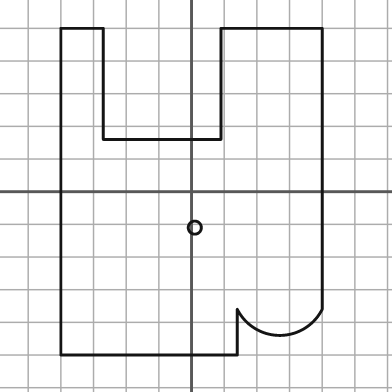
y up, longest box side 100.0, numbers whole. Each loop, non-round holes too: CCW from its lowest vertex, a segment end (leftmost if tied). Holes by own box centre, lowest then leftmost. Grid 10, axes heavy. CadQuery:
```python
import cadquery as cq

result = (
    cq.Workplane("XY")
    .moveTo(-40.0, -50.0)
    .lineTo(14.0, -50.0)
    .lineTo(14.0, -36.0)
    .threePointArc((27.0, -44.0), (40.0, -36.0))
    .lineTo(40.0, 50.0)
    .lineTo(9.0, 50.0)
    .lineTo(9.0, 16.0)
    .lineTo(-27.0, 16.0)
    .lineTo(-27.0, 50.0)
    .lineTo(-40.0, 50.0)
    .close()
    .moveTo(1.0, -11.0)
    .circle(2.0)
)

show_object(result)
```